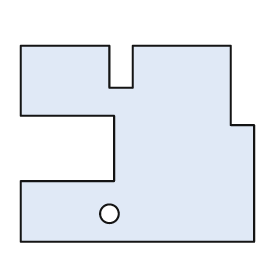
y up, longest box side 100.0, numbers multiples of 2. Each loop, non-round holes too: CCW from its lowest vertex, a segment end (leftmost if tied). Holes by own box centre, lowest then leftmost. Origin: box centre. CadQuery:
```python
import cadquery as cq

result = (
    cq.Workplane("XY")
    .moveTo(-50.0, -42.0)
    .lineTo(50.0, -42.0)
    .lineTo(50.0, 8.0)
    .lineTo(40.0, 8.0)
    .lineTo(40.0, 42.0)
    .lineTo(-2.0, 42.0)
    .lineTo(-2.0, 24.0)
    .lineTo(-12.0, 24.0)
    .lineTo(-12.0, 42.0)
    .lineTo(-50.0, 42.0)
    .lineTo(-50.0, 12.0)
    .lineTo(-10.0, 12.0)
    .lineTo(-10.0, -16.0)
    .lineTo(-50.0, -16.0)
    .close()
    .moveTo(-12.0, -30.0)
    .circle(4.0)
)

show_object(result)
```